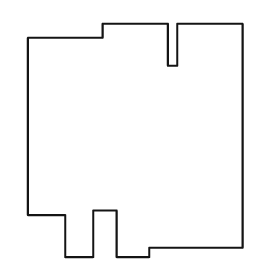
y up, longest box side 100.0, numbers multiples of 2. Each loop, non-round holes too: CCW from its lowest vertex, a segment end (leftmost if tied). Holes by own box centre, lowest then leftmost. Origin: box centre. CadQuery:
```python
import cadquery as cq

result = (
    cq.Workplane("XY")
    .moveTo(-30.0, -50.0)
    .lineTo(-18.0, -50.0)
    .lineTo(-18.0, -30.0)
    .lineTo(-8.0, -30.0)
    .lineTo(-8.0, -50.0)
    .lineTo(6.0, -50.0)
    .lineTo(6.0, -46.0)
    .lineTo(46.0, -46.0)
    .lineTo(46.0, 50.0)
    .lineTo(18.0, 50.0)
    .lineTo(18.0, 32.0)
    .lineTo(14.0, 32.0)
    .lineTo(14.0, 50.0)
    .lineTo(-14.0, 50.0)
    .lineTo(-14.0, 44.0)
    .lineTo(-46.0, 44.0)
    .lineTo(-46.0, -32.0)
    .lineTo(-30.0, -32.0)
    .close()
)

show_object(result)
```